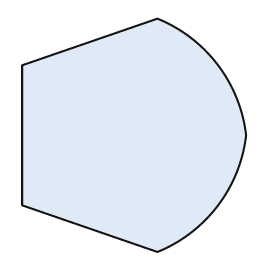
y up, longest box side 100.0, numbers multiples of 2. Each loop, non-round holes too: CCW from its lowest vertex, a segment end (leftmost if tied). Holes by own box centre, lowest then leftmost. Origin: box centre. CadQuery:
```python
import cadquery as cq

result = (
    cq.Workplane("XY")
    .moveTo(10.0, -50.0)
    .threePointArc((36.0, -30.0), (48.0, 0.0))
    .threePointArc((36.0, 30.0), (10.0, 50.0))
    .lineTo(-48.0, 30.0)
    .lineTo(-48.0, -30.0)
    .close()
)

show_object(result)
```